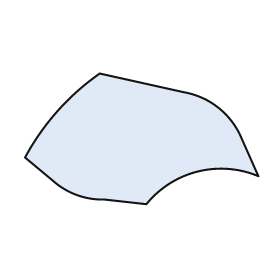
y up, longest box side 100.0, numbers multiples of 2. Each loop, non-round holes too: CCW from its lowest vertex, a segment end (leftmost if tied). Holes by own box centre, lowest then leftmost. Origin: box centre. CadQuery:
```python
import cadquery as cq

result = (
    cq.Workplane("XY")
    .moveTo(2.0, -28.0)
    .threePointArc((24.0, -14.0), (50.0, -16.0))
    .lineTo(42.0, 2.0)
    .threePointArc((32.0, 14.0), (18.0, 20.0))
    .lineTo(-18.0, 28.0)
    .threePointArc((-36.0, 12.0), (-50.0, -8.0))
    .lineTo(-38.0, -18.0)
    .threePointArc((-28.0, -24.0), (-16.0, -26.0))
    .close()
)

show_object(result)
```